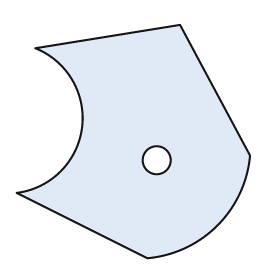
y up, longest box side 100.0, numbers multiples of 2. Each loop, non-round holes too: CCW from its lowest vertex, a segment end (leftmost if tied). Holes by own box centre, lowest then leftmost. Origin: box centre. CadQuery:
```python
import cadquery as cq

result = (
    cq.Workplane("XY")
    .moveTo(6.0, -50.0)
    .threePointArc((36.0, -36.0), (50.0, -6.0))
    .lineTo(20.0, 50.0)
    .lineTo(-42.0, 40.0)
    .threePointArc((-22.0, 6.0), (-50.0, -22.0))
    .close()
    .moveTo(10.0, -8.0)
    .circle(6.0)
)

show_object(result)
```